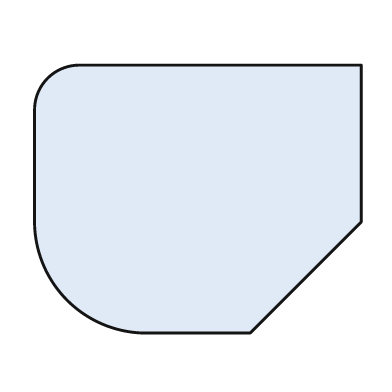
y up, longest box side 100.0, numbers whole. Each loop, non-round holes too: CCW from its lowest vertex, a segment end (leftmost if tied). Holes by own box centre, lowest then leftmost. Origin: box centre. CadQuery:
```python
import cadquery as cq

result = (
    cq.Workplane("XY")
    .moveTo(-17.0, -41.0)
    .lineTo(16.0, -41.0)
    .lineTo(50.0, -7.0)
    .lineTo(50.0, 41.0)
    .lineTo(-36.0, 41.0)
    .threePointArc((-46.0, 37.0), (-50.0, 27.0))
    .lineTo(-50.0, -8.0)
    .threePointArc((-40.0, -31.0), (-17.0, -41.0))
    .close()
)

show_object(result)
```